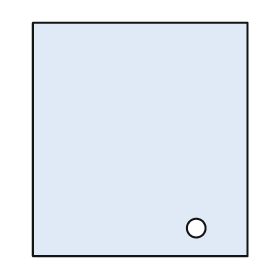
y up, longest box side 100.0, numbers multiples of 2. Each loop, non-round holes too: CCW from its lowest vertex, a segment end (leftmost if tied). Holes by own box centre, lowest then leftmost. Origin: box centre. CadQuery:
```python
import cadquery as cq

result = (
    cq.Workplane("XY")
    .moveTo(-46.0, -50.0)
    .lineTo(46.0, -50.0)
    .lineTo(46.0, 50.0)
    .lineTo(-46.0, 50.0)
    .close()
    .moveTo(24.0, -38.0)
    .circle(4.0)
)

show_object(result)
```